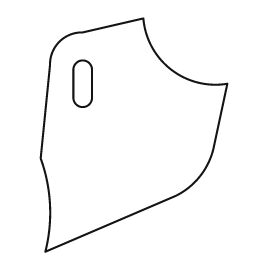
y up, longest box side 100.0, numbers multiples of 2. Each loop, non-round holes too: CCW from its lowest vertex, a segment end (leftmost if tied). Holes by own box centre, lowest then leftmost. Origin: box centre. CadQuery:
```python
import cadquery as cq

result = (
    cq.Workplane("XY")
    .moveTo(-38.0, -50.0)
    .lineTo(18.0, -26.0)
    .threePointArc((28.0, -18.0), (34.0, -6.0))
    .lineTo(40.0, 22.0)
    .threePointArc((16.0, 28.0), (4.0, 50.0))
    .lineTo(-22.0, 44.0)
    .threePointArc((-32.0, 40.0), (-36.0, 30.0))
    .lineTo(-40.0, -10.0)
    .threePointArc((-36.0, -30.0), (-38.0, -50.0))
    .close()
    .moveTo(-26.0, 16.0)
    .threePointArc((-22.0, 12.0), (-18.0, 16.0))
    .lineTo(-18.0, 28.0)
    .threePointArc((-22.0, 32.0), (-26.0, 28.0))
    .close()
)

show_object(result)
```